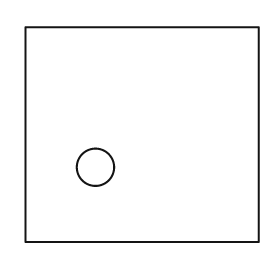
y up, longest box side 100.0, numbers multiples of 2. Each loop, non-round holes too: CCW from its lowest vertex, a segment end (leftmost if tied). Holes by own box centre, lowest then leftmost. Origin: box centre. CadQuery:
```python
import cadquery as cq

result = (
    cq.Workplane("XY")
    .moveTo(-50.0, -46.0)
    .lineTo(50.0, -46.0)
    .lineTo(50.0, 46.0)
    .lineTo(-50.0, 46.0)
    .close()
    .moveTo(-20.0, -14.0)
    .circle(8.0)
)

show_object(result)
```